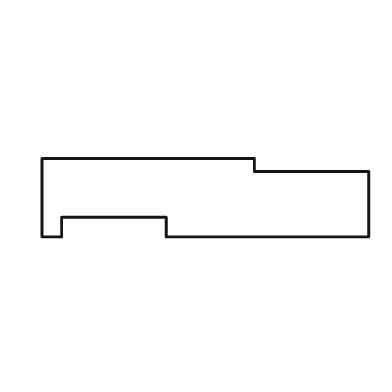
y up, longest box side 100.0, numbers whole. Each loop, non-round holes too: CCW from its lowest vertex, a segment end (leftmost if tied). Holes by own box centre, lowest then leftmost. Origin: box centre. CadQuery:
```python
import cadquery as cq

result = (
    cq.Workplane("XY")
    .moveTo(-50.0, -12.0)
    .lineTo(-44.0, -12.0)
    .lineTo(-44.0, -6.0)
    .lineTo(-12.0, -6.0)
    .lineTo(-12.0, -12.0)
    .lineTo(50.0, -12.0)
    .lineTo(50.0, 8.0)
    .lineTo(15.0, 8.0)
    .lineTo(15.0, 12.0)
    .lineTo(-50.0, 12.0)
    .close()
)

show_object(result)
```